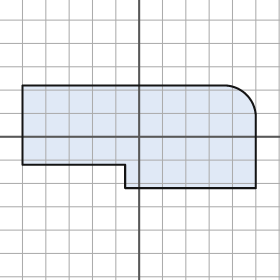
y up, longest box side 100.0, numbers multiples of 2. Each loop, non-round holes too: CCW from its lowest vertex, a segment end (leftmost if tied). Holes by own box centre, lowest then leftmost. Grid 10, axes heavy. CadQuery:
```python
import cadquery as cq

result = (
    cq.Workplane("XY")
    .moveTo(-6.0, -22.0)
    .lineTo(50.0, -22.0)
    .lineTo(50.0, 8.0)
    .threePointArc((46.0, 18.0), (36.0, 22.0))
    .lineTo(-50.0, 22.0)
    .lineTo(-50.0, -12.0)
    .lineTo(-6.0, -12.0)
    .close()
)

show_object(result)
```